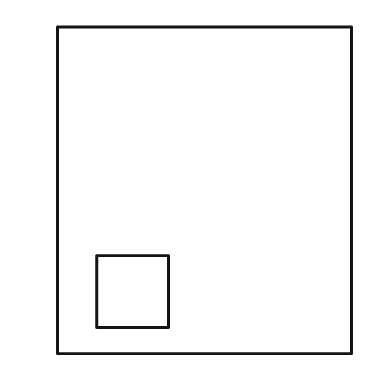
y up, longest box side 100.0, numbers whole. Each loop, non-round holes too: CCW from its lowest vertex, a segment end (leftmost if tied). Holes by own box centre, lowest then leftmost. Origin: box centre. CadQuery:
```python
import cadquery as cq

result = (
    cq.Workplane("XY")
    .moveTo(-45.0, -50.0)
    .lineTo(45.0, -50.0)
    .lineTo(45.0, 50.0)
    .lineTo(-45.0, 50.0)
    .close()
    .moveTo(-33.0, -42.0)
    .lineTo(-11.0, -42.0)
    .lineTo(-11.0, -20.0)
    .lineTo(-33.0, -20.0)
    .close()
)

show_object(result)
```